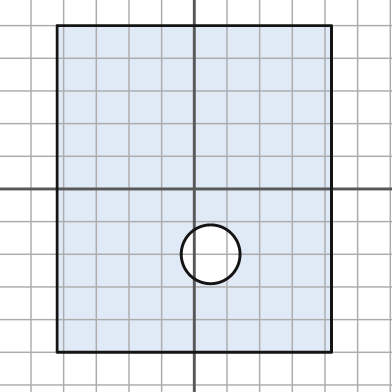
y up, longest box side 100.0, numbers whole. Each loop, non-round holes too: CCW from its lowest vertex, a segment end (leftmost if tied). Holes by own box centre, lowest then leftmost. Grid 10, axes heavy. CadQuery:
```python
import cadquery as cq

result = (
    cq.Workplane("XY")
    .moveTo(-42.0, -50.0)
    .lineTo(42.0, -50.0)
    .lineTo(42.0, 50.0)
    .lineTo(-42.0, 50.0)
    .close()
    .moveTo(5.0, -20.0)
    .circle(9.0)
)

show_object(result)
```